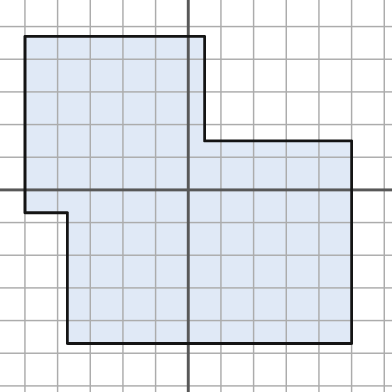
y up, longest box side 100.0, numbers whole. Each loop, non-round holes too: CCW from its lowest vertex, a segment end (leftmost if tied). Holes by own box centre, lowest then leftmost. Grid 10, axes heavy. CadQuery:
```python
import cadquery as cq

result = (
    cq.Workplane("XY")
    .moveTo(-37.0, -47.0)
    .lineTo(50.0, -47.0)
    .lineTo(50.0, 15.0)
    .lineTo(5.0, 15.0)
    .lineTo(5.0, 47.0)
    .lineTo(-50.0, 47.0)
    .lineTo(-50.0, -7.0)
    .lineTo(-37.0, -7.0)
    .close()
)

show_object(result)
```